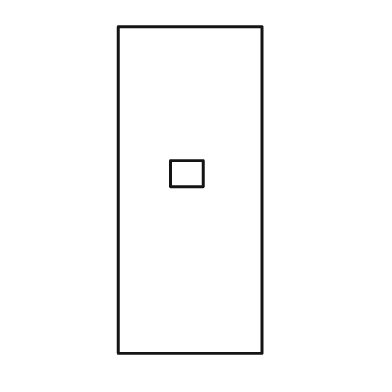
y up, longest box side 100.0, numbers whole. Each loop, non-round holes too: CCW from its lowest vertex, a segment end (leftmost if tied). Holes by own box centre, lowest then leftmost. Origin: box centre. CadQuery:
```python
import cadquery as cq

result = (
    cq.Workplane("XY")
    .moveTo(-22.0, -50.0)
    .lineTo(22.0, -50.0)
    .lineTo(22.0, 50.0)
    .lineTo(-22.0, 50.0)
    .close()
    .moveTo(-6.0, 1.0)
    .lineTo(4.0, 1.0)
    .lineTo(4.0, 9.0)
    .lineTo(-6.0, 9.0)
    .close()
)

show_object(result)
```